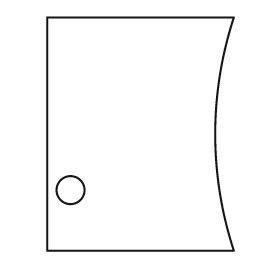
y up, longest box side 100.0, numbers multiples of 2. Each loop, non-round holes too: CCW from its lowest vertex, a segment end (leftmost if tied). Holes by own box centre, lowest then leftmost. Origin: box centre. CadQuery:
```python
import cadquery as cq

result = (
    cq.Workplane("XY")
    .moveTo(-40.0, -50.0)
    .lineTo(40.0, -50.0)
    .threePointArc((32.0, 0.0), (40.0, 50.0))
    .lineTo(-40.0, 50.0)
    .close()
    .moveTo(-30.0, -24.0)
    .circle(6.0)
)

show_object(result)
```